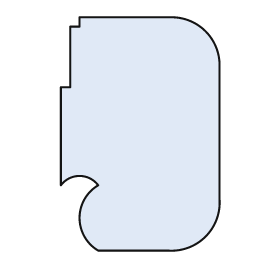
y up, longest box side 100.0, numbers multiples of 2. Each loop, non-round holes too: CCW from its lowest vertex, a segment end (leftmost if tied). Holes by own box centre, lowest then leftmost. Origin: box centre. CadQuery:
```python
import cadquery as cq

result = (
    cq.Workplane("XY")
    .moveTo(-18.0, -50.0)
    .lineTo(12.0, -50.0)
    .threePointArc((28.0, -44.0), (34.0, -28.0))
    .lineTo(34.0, 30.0)
    .threePointArc((28.0, 44.0), (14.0, 50.0))
    .lineTo(-26.0, 50.0)
    .lineTo(-26.0, 46.0)
    .lineTo(-30.0, 46.0)
    .lineTo(-30.0, 20.0)
    .lineTo(-34.0, 20.0)
    .lineTo(-34.0, -22.0)
    .threePointArc((-26.0, -18.0), (-18.0, -22.0))
    .threePointArc((-26.0, -36.0), (-18.0, -50.0))
    .close()
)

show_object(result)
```